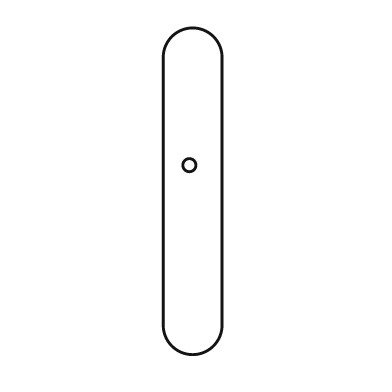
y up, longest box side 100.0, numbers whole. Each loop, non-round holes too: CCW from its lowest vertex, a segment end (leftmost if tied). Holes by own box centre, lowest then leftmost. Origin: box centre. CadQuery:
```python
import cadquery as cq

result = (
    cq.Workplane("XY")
    .moveTo(-9.0, -41.0)
    .threePointArc((0.0, -50.0), (9.0, -41.0))
    .lineTo(9.0, 41.0)
    .threePointArc((0.0, 50.0), (-9.0, 41.0))
    .close()
    .moveTo(-1.0, 8.0)
    .circle(2.0)
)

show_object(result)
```